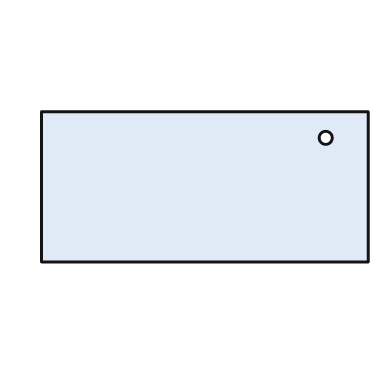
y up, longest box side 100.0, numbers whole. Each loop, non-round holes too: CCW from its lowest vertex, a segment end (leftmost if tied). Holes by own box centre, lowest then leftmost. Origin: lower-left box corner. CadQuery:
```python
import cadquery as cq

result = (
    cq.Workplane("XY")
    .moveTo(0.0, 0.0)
    .lineTo(100.0, 0.0)
    .lineTo(100.0, 46.0)
    .lineTo(0.0, 46.0)
    .close()
    .moveTo(87.0, 38.0)
    .circle(2.0)
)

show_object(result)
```